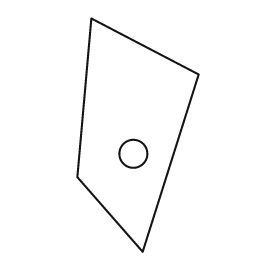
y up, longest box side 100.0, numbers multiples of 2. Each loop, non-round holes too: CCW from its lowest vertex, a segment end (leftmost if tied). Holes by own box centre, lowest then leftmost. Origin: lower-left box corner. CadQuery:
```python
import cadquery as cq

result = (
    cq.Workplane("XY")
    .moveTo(28.0, 0.0)
    .lineTo(52.0, 76.0)
    .lineTo(6.0, 100.0)
    .lineTo(0.0, 32.0)
    .close()
    .moveTo(24.0, 42.0)
    .circle(6.0)
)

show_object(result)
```